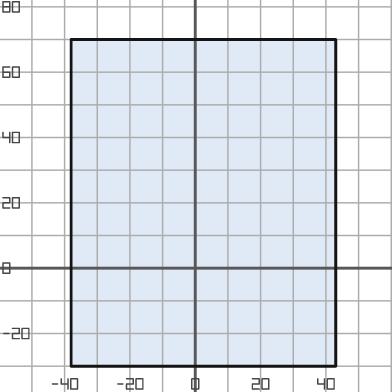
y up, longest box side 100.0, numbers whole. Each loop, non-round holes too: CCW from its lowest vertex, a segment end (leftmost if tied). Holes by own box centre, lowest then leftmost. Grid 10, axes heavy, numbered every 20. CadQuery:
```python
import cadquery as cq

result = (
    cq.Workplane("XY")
    .moveTo(-38.0, -30.0)
    .lineTo(43.0, -30.0)
    .lineTo(43.0, 70.0)
    .lineTo(-38.0, 70.0)
    .close()
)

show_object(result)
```